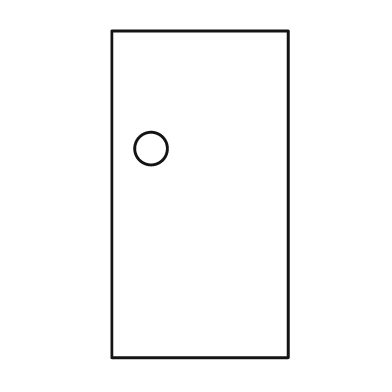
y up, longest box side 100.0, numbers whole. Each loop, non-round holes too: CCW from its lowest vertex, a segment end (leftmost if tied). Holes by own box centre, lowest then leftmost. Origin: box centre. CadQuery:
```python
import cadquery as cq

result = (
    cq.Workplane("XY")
    .moveTo(-27.0, -50.0)
    .lineTo(27.0, -50.0)
    .lineTo(27.0, 50.0)
    .lineTo(-27.0, 50.0)
    .close()
    .moveTo(-15.0, 14.0)
    .circle(5.0)
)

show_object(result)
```